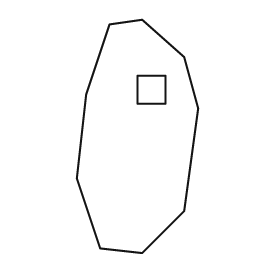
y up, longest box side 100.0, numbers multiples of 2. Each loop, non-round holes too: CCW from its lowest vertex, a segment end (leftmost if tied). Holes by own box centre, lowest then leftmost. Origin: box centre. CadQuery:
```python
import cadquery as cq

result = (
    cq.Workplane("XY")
    .moveTo(2.0, -50.0)
    .lineTo(20.0, -32.0)
    .lineTo(26.0, 12.0)
    .lineTo(20.0, 34.0)
    .lineTo(2.0, 50.0)
    .lineTo(-12.0, 48.0)
    .lineTo(-22.0, 18.0)
    .lineTo(-26.0, -18.0)
    .lineTo(-16.0, -48.0)
    .close()
    .moveTo(0.0, 14.0)
    .lineTo(12.0, 14.0)
    .lineTo(12.0, 26.0)
    .lineTo(0.0, 26.0)
    .close()
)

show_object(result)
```